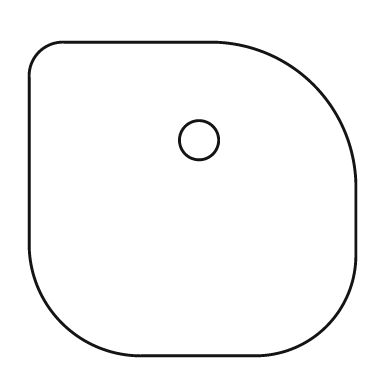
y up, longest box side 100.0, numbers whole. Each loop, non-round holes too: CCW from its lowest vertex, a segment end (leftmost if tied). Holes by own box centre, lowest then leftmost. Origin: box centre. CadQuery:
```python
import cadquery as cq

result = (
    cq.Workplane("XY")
    .moveTo(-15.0, -48.0)
    .lineTo(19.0, -48.0)
    .threePointArc((41.0, -39.0), (50.0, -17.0))
    .lineTo(50.0, 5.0)
    .threePointArc((37.0, 35.0), (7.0, 48.0))
    .lineTo(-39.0, 48.0)
    .threePointArc((-47.0, 45.0), (-50.0, 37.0))
    .lineTo(-50.0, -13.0)
    .threePointArc((-40.0, -38.0), (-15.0, -48.0))
    .close()
    .moveTo(2.0, 18.0)
    .circle(6.0)
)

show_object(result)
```